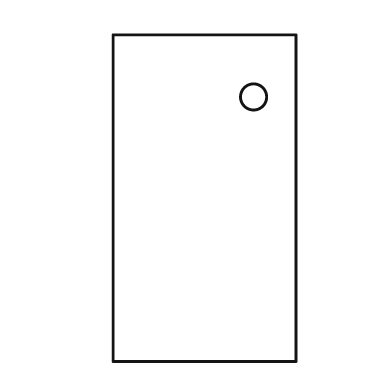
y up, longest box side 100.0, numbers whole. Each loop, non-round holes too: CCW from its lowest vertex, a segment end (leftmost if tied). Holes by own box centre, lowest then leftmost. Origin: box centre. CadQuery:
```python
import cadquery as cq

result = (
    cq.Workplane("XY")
    .moveTo(-28.0, -50.0)
    .lineTo(28.0, -50.0)
    .lineTo(28.0, 50.0)
    .lineTo(-28.0, 50.0)
    .close()
    .moveTo(15.0, 31.0)
    .circle(4.0)
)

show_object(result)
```